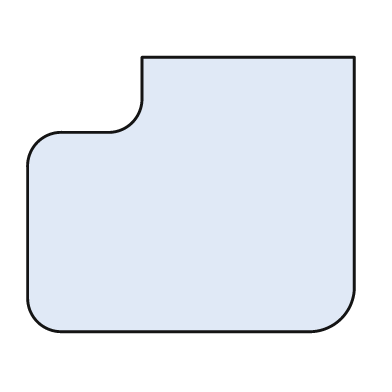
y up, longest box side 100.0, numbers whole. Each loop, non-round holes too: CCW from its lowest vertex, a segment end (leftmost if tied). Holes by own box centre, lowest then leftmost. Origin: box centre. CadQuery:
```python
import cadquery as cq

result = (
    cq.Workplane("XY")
    .moveTo(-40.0, -42.0)
    .lineTo(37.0, -42.0)
    .threePointArc((46.0, -38.0), (50.0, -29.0))
    .lineTo(50.0, 42.0)
    .lineTo(-15.0, 42.0)
    .lineTo(-15.0, 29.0)
    .threePointArc((-18.0, 22.0), (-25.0, 19.0))
    .lineTo(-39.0, 19.0)
    .threePointArc((-47.0, 16.0), (-50.0, 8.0))
    .lineTo(-50.0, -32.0)
    .threePointArc((-47.0, -39.0), (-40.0, -42.0))
    .close()
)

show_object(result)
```